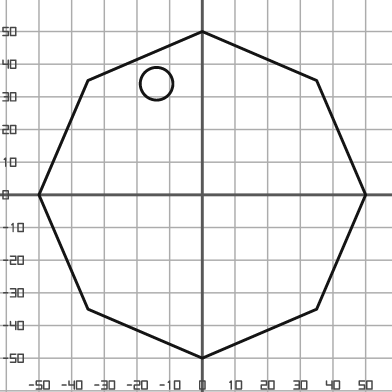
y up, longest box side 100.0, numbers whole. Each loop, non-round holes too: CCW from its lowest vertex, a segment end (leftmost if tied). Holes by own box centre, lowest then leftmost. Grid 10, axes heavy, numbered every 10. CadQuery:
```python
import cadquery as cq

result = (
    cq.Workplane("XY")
    .moveTo(0.0, -50.0)
    .lineTo(35.0, -35.0)
    .lineTo(50.0, 0.0)
    .lineTo(35.0, 35.0)
    .lineTo(0.0, 50.0)
    .lineTo(-35.0, 35.0)
    .lineTo(-50.0, 0.0)
    .lineTo(-35.0, -35.0)
    .close()
    .moveTo(-14.0, 34.0)
    .circle(5.0)
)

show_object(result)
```